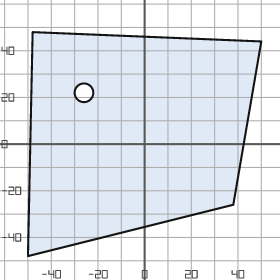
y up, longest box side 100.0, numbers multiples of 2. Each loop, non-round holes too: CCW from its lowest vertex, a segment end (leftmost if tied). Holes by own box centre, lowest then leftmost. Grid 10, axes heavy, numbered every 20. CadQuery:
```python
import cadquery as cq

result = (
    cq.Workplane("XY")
    .moveTo(-50.0, -48.0)
    .lineTo(38.0, -26.0)
    .lineTo(50.0, 44.0)
    .lineTo(-48.0, 48.0)
    .close()
    .moveTo(-26.0, 22.0)
    .circle(4.0)
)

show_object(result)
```